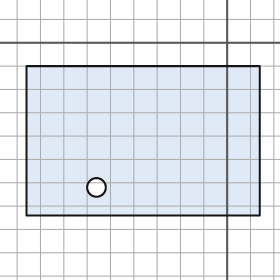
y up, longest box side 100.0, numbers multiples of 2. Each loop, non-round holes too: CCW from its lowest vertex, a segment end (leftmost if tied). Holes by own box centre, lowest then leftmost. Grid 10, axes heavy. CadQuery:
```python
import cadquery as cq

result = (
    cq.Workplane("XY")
    .moveTo(-86.0, -74.0)
    .lineTo(14.0, -74.0)
    .lineTo(14.0, -10.0)
    .lineTo(-86.0, -10.0)
    .close()
    .moveTo(-56.0, -62.0)
    .circle(4.0)
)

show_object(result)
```